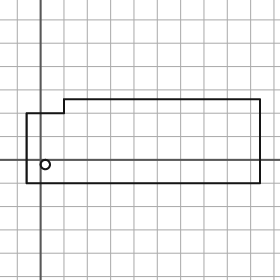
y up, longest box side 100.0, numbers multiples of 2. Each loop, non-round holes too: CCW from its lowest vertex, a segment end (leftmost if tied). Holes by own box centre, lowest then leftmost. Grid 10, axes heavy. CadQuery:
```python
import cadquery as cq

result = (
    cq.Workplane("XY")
    .moveTo(-6.0, -10.0)
    .lineTo(94.0, -10.0)
    .lineTo(94.0, 26.0)
    .lineTo(10.0, 26.0)
    .lineTo(10.0, 20.0)
    .lineTo(-6.0, 20.0)
    .close()
    .moveTo(2.0, -2.0)
    .circle(2.0)
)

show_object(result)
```